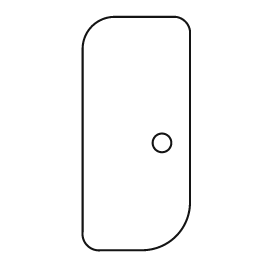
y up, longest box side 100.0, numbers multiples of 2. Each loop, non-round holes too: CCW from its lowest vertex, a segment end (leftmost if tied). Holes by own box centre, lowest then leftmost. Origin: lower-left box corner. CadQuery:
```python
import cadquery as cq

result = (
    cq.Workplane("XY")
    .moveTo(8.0, 0.0)
    .lineTo(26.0, 0.0)
    .threePointArc((40.0, 6.0), (46.0, 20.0))
    .lineTo(46.0, 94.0)
    .threePointArc((44.0, 98.0), (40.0, 100.0))
    .lineTo(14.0, 100.0)
    .threePointArc((4.0, 96.0), (0.0, 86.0))
    .lineTo(0.0, 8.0)
    .threePointArc((2.0, 2.0), (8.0, 0.0))
    .close()
    .moveTo(34.0, 46.0)
    .circle(4.0)
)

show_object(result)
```